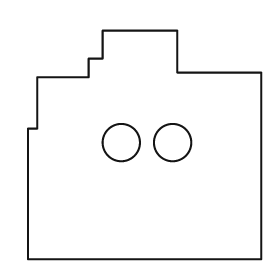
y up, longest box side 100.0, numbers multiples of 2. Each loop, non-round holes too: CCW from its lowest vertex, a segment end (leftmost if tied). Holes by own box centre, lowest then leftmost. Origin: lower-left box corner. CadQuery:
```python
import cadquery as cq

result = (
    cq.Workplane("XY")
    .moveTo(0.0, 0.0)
    .lineTo(100.0, 0.0)
    .lineTo(100.0, 80.0)
    .lineTo(64.0, 80.0)
    .lineTo(64.0, 98.0)
    .lineTo(32.0, 98.0)
    .lineTo(32.0, 86.0)
    .lineTo(26.0, 86.0)
    .lineTo(26.0, 78.0)
    .lineTo(4.0, 78.0)
    .lineTo(4.0, 56.0)
    .lineTo(0.0, 56.0)
    .close()
    .moveTo(40.0, 50.0)
    .circle(8.0)
    .moveTo(62.0, 50.0)
    .circle(8.0)
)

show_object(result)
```